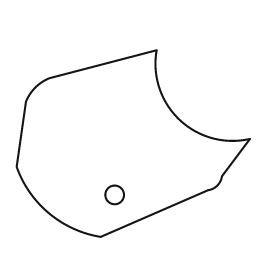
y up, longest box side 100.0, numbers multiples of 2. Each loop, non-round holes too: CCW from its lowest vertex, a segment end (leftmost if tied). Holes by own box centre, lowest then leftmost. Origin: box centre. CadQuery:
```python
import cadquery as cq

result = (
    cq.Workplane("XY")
    .moveTo(-14.0, -40.0)
    .lineTo(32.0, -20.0)
    .threePointArc((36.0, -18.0), (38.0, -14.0))
    .lineTo(50.0, 2.0)
    .threePointArc((20.0, 10.0), (10.0, 40.0))
    .lineTo(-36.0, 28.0)
    .threePointArc((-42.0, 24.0), (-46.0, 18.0))
    .lineTo(-50.0, -10.0)
    .threePointArc((-36.0, -30.0), (-14.0, -40.0))
    .close()
    .moveTo(-8.0, -22.0)
    .circle(4.0)
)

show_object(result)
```